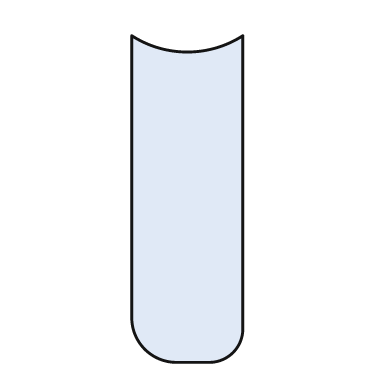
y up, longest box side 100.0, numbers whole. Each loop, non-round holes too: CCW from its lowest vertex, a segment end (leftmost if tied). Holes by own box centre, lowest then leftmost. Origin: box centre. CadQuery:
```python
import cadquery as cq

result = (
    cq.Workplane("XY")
    .moveTo(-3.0, -50.0)
    .lineTo(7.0, -50.0)
    .threePointArc((14.0, -47.0), (17.0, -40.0))
    .lineTo(17.0, 50.0)
    .threePointArc((0.0, 45.0), (-17.0, 50.0))
    .lineTo(-17.0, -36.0)
    .threePointArc((-13.0, -46.0), (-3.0, -50.0))
    .close()
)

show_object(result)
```